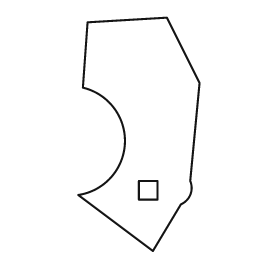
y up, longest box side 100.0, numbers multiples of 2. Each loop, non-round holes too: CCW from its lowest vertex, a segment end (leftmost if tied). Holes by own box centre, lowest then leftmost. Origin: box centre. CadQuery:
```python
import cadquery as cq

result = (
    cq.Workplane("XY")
    .moveTo(6.0, -50.0)
    .lineTo(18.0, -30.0)
    .threePointArc((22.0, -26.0), (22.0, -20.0))
    .lineTo(26.0, 22.0)
    .lineTo(12.0, 50.0)
    .lineTo(-22.0, 48.0)
    .lineTo(-24.0, 20.0)
    .threePointArc((-6.0, -4.0), (-26.0, -26.0))
    .close()
    .moveTo(0.0, -28.0)
    .lineTo(8.0, -28.0)
    .lineTo(8.0, -20.0)
    .lineTo(0.0, -20.0)
    .close()
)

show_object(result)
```